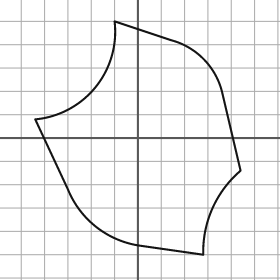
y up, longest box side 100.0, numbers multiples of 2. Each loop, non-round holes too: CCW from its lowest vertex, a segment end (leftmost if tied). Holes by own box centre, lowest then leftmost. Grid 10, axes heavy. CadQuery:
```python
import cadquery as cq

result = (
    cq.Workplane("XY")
    .moveTo(28.0, -50.0)
    .threePointArc((32.0, -30.0), (44.0, -14.0))
    .lineTo(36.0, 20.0)
    .threePointArc((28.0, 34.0), (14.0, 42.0))
    .lineTo(-10.0, 50.0)
    .threePointArc((-18.0, 22.0), (-44.0, 8.0))
    .lineTo(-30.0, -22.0)
    .threePointArc((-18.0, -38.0), (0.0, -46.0))
    .close()
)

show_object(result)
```